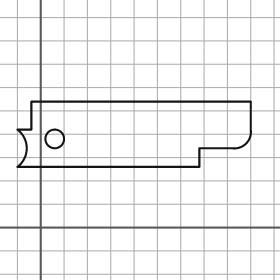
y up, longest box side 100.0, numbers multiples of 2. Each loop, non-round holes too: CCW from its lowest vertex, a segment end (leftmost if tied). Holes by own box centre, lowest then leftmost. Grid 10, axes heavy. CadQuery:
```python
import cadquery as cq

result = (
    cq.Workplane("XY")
    .moveTo(-10.0, 26.0)
    .lineTo(68.0, 26.0)
    .lineTo(68.0, 34.0)
    .lineTo(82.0, 34.0)
    .threePointArc((88.0, 36.0), (90.0, 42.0))
    .lineTo(90.0, 54.0)
    .lineTo(-4.0, 54.0)
    .lineTo(-4.0, 42.0)
    .lineTo(-10.0, 42.0)
    .threePointArc((-6.0, 34.0), (-10.0, 26.0))
    .close()
    .moveTo(6.0, 38.0)
    .circle(4.0)
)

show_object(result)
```